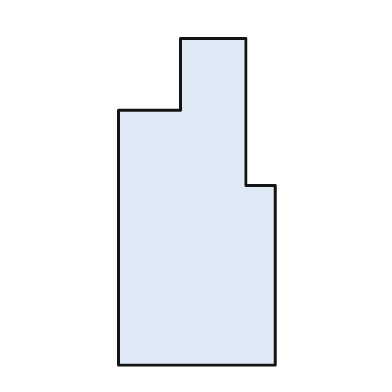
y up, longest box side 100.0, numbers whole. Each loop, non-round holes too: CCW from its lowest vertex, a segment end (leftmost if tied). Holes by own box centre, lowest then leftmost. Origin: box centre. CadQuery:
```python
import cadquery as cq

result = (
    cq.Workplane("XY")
    .moveTo(-24.0, -50.0)
    .lineTo(24.0, -50.0)
    .lineTo(24.0, 5.0)
    .lineTo(15.0, 5.0)
    .lineTo(15.0, 50.0)
    .lineTo(-5.0, 50.0)
    .lineTo(-5.0, 28.0)
    .lineTo(-24.0, 28.0)
    .close()
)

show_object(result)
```